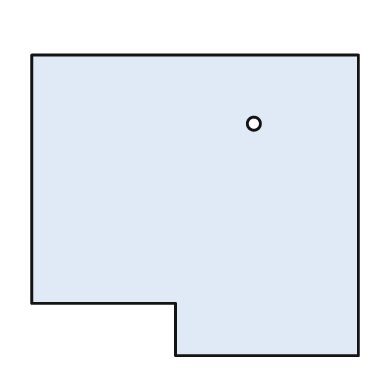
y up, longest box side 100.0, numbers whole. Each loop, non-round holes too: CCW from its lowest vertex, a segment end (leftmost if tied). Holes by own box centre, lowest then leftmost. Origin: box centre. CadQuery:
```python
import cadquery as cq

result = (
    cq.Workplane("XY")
    .moveTo(-6.0, -46.0)
    .lineTo(50.0, -46.0)
    .lineTo(50.0, 46.0)
    .lineTo(-50.0, 46.0)
    .lineTo(-50.0, -30.0)
    .lineTo(-6.0, -30.0)
    .close()
    .moveTo(18.0, 25.0)
    .circle(2.0)
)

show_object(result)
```